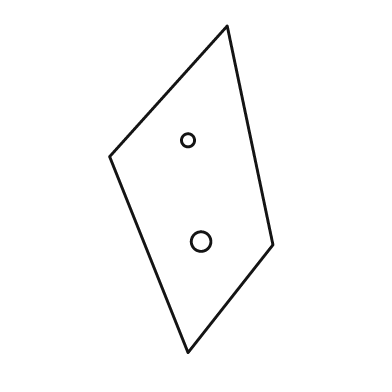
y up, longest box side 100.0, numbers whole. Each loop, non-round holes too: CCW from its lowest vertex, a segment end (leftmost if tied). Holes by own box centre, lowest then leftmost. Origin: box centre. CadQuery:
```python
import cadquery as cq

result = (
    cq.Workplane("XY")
    .moveTo(-1.0, -50.0)
    .lineTo(25.0, -17.0)
    .lineTo(11.0, 50.0)
    .lineTo(-25.0, 10.0)
    .close()
    .moveTo(3.0, -16.0)
    .circle(3.0)
    .moveTo(-1.0, 15.0)
    .circle(2.0)
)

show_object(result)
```